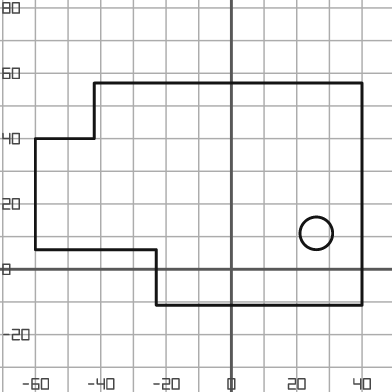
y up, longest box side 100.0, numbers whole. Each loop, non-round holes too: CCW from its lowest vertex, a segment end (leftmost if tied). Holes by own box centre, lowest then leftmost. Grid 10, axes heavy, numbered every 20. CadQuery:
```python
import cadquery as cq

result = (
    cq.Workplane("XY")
    .moveTo(-23.0, -11.0)
    .lineTo(40.0, -11.0)
    .lineTo(40.0, 57.0)
    .lineTo(-42.0, 57.0)
    .lineTo(-42.0, 40.0)
    .lineTo(-60.0, 40.0)
    .lineTo(-60.0, 6.0)
    .lineTo(-23.0, 6.0)
    .close()
    .moveTo(26.0, 11.0)
    .circle(5.0)
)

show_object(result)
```